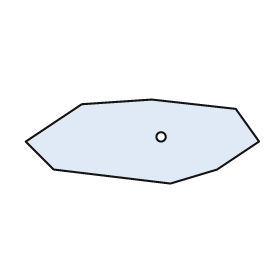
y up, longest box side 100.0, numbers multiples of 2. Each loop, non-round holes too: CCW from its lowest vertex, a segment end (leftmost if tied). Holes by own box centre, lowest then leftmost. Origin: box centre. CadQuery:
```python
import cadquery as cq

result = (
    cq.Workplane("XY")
    .moveTo(12.0, -18.0)
    .lineTo(32.0, -12.0)
    .lineTo(50.0, 0.0)
    .lineTo(40.0, 14.0)
    .lineTo(4.0, 18.0)
    .lineTo(-26.0, 16.0)
    .lineTo(-50.0, 0.0)
    .lineTo(-38.0, -12.0)
    .close()
    .moveTo(8.0, 2.0)
    .circle(2.0)
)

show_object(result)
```